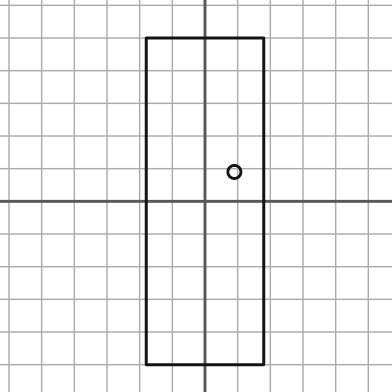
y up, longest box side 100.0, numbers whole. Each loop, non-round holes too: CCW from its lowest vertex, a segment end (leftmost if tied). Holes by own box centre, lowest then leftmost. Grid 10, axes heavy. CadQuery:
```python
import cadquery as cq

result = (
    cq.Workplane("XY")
    .moveTo(-18.0, -50.0)
    .lineTo(18.0, -50.0)
    .lineTo(18.0, 50.0)
    .lineTo(-18.0, 50.0)
    .close()
    .moveTo(9.0, 9.0)
    .circle(2.0)
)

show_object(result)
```